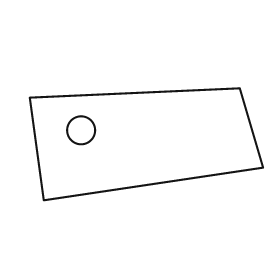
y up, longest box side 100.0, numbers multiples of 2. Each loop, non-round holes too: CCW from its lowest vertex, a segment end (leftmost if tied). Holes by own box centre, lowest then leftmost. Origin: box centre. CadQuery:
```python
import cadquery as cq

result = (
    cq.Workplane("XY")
    .moveTo(-44.0, -24.0)
    .lineTo(50.0, -10.0)
    .lineTo(40.0, 24.0)
    .lineTo(-50.0, 20.0)
    .close()
    .moveTo(-28.0, 6.0)
    .circle(6.0)
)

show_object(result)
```